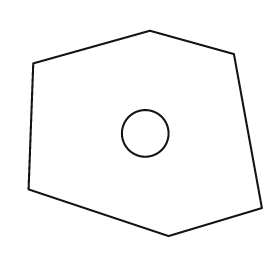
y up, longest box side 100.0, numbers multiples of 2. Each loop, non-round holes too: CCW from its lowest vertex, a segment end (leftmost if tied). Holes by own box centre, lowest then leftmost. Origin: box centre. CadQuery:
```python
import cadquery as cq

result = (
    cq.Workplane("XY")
    .moveTo(10.0, -44.0)
    .lineTo(50.0, -32.0)
    .lineTo(38.0, 34.0)
    .lineTo(2.0, 44.0)
    .lineTo(-48.0, 30.0)
    .lineTo(-50.0, -24.0)
    .close()
    .moveTo(0.0, 0.0)
    .circle(10.0)
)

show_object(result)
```